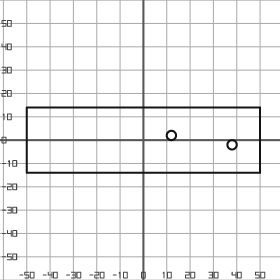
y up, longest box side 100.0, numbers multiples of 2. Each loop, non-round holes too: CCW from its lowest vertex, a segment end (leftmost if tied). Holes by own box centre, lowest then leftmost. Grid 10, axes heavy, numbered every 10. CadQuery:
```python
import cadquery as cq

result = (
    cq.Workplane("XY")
    .moveTo(-50.0, -14.0)
    .lineTo(50.0, -14.0)
    .lineTo(50.0, 14.0)
    .lineTo(-50.0, 14.0)
    .close()
    .moveTo(38.0, -2.0)
    .circle(2.0)
    .moveTo(12.0, 2.0)
    .circle(2.0)
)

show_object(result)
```